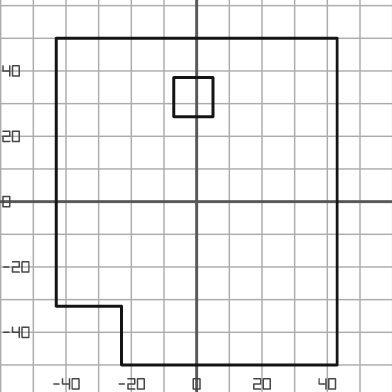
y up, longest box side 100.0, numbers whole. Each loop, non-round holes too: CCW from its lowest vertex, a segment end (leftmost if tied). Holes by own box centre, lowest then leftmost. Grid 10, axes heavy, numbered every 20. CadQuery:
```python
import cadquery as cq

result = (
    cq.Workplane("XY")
    .moveTo(-23.0, -50.0)
    .lineTo(43.0, -50.0)
    .lineTo(43.0, 50.0)
    .lineTo(-43.0, 50.0)
    .lineTo(-43.0, -32.0)
    .lineTo(-23.0, -32.0)
    .close()
    .moveTo(-7.0, 26.0)
    .lineTo(5.0, 26.0)
    .lineTo(5.0, 38.0)
    .lineTo(-7.0, 38.0)
    .close()
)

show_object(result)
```